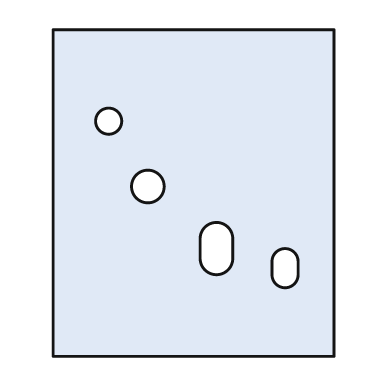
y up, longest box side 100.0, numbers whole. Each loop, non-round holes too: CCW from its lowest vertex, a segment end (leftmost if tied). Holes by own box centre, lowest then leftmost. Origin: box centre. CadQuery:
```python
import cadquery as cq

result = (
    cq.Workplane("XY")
    .moveTo(-43.0, -50.0)
    .lineTo(43.0, -50.0)
    .lineTo(43.0, 50.0)
    .lineTo(-43.0, 50.0)
    .close()
    .moveTo(24.0, -25.0)
    .threePointArc((28.0, -29.0), (32.0, -25.0))
    .lineTo(32.0, -21.0)
    .threePointArc((28.0, -17.0), (24.0, -21.0))
    .close()
    .moveTo(2.0, -20.0)
    .threePointArc((7.0, -25.0), (12.0, -20.0))
    .lineTo(12.0, -14.0)
    .threePointArc((7.0, -9.0), (2.0, -14.0))
    .close()
    .moveTo(-14.0, 2.0)
    .circle(5.0)
    .moveTo(-26.0, 22.0)
    .circle(4.0)
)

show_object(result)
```